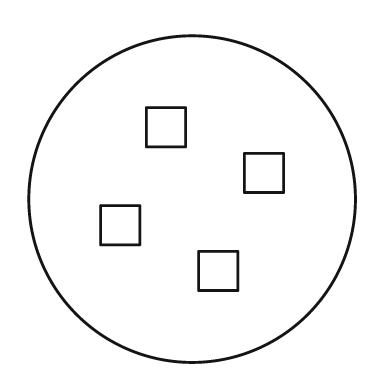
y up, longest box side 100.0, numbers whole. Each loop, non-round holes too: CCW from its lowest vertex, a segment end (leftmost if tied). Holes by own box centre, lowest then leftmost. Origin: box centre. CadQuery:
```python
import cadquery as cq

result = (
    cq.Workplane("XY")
    .moveTo(0.0, 0.0)
    .circle(50.0)
    .moveTo(2.0, -28.0)
    .lineTo(14.0, -28.0)
    .lineTo(14.0, -16.0)
    .lineTo(2.0, -16.0)
    .close()
    .moveTo(-28.0, -14.0)
    .lineTo(-16.0, -14.0)
    .lineTo(-16.0, -2.0)
    .lineTo(-28.0, -2.0)
    .close()
    .moveTo(16.0, 2.0)
    .lineTo(28.0, 2.0)
    .lineTo(28.0, 14.0)
    .lineTo(16.0, 14.0)
    .close()
    .moveTo(-14.0, 16.0)
    .lineTo(-2.0, 16.0)
    .lineTo(-2.0, 28.0)
    .lineTo(-14.0, 28.0)
    .close()
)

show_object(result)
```